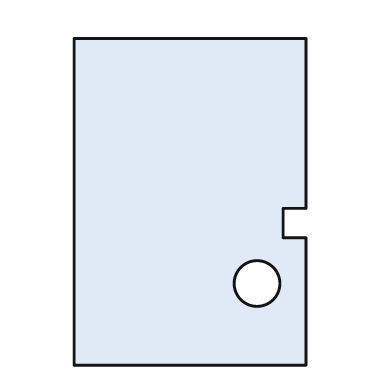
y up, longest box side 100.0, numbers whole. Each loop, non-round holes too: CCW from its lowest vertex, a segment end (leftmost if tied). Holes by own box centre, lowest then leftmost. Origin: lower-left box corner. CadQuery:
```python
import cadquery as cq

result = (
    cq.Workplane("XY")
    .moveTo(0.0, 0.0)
    .lineTo(71.0, 0.0)
    .lineTo(71.0, 39.0)
    .lineTo(64.0, 39.0)
    .lineTo(64.0, 48.0)
    .lineTo(71.0, 48.0)
    .lineTo(71.0, 100.0)
    .lineTo(0.0, 100.0)
    .close()
    .moveTo(56.0, 25.0)
    .circle(7.0)
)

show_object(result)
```